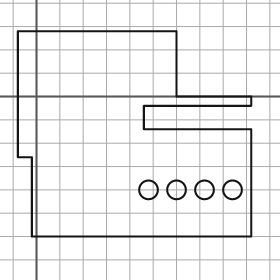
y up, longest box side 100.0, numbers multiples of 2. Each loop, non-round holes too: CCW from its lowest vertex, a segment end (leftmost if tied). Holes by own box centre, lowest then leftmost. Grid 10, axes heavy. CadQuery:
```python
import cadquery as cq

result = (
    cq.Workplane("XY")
    .moveTo(-2.0, -60.0)
    .lineTo(92.0, -60.0)
    .lineTo(92.0, -14.0)
    .lineTo(46.0, -14.0)
    .lineTo(46.0, -4.0)
    .lineTo(92.0, -4.0)
    .lineTo(92.0, 0.0)
    .lineTo(60.0, 0.0)
    .lineTo(60.0, 28.0)
    .lineTo(-8.0, 28.0)
    .lineTo(-8.0, -26.0)
    .lineTo(-2.0, -26.0)
    .close()
    .moveTo(48.0, -40.0)
    .circle(4.0)
    .moveTo(60.0, -40.0)
    .circle(4.0)
    .moveTo(72.0, -40.0)
    .circle(4.0)
    .moveTo(84.0, -40.0)
    .circle(4.0)
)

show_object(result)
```